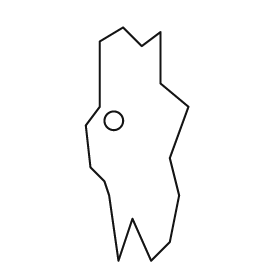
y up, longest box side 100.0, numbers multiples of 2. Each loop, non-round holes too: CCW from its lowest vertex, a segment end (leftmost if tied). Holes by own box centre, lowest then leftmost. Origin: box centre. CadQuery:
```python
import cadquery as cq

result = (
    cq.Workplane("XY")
    .moveTo(-8.0, -50.0)
    .lineTo(-2.0, -32.0)
    .lineTo(6.0, -50.0)
    .lineTo(14.0, -42.0)
    .lineTo(18.0, -22.0)
    .lineTo(14.0, -6.0)
    .lineTo(22.0, 16.0)
    .lineTo(10.0, 26.0)
    .lineTo(10.0, 48.0)
    .lineTo(2.0, 42.0)
    .lineTo(-6.0, 50.0)
    .lineTo(-16.0, 44.0)
    .lineTo(-16.0, 16.0)
    .lineTo(-22.0, 8.0)
    .lineTo(-20.0, -10.0)
    .lineTo(-14.0, -16.0)
    .lineTo(-12.0, -22.0)
    .close()
    .moveTo(-10.0, 10.0)
    .circle(4.0)
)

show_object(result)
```